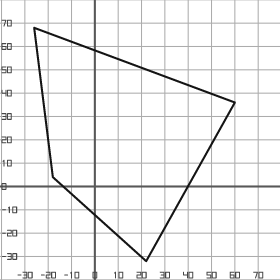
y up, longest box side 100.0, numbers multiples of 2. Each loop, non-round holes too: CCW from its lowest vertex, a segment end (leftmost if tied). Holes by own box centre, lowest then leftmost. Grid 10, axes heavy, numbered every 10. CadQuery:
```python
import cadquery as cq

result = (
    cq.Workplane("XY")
    .moveTo(22.0, -32.0)
    .lineTo(60.0, 36.0)
    .lineTo(-26.0, 68.0)
    .lineTo(-18.0, 4.0)
    .close()
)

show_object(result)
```